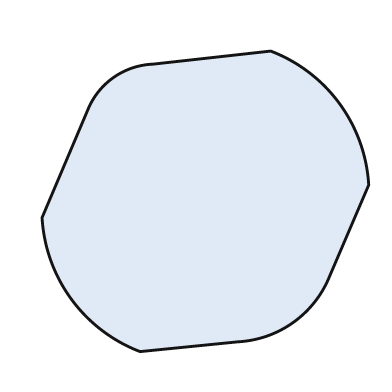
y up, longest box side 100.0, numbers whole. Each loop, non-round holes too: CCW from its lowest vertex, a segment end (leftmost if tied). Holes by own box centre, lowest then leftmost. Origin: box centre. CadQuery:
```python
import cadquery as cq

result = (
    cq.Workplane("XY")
    .moveTo(-20.0, -46.0)
    .lineTo(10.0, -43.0)
    .threePointArc((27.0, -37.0), (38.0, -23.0))
    .lineTo(50.0, 5.0)
    .threePointArc((41.0, 30.0), (20.0, 46.0))
    .lineTo(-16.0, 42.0)
    .threePointArc((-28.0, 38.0), (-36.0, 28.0))
    .lineTo(-50.0, -5.0)
    .threePointArc((-41.0, -30.0), (-20.0, -46.0))
    .close()
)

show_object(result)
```